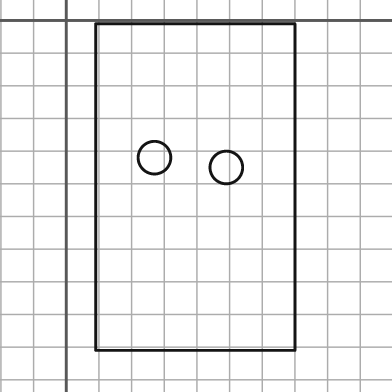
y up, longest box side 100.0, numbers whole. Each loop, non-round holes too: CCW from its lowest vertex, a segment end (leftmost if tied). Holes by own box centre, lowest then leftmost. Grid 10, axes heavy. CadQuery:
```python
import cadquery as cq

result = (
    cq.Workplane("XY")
    .moveTo(9.0, -101.0)
    .lineTo(70.0, -101.0)
    .lineTo(70.0, -1.0)
    .lineTo(9.0, -1.0)
    .close()
    .moveTo(49.0, -45.0)
    .circle(5.0)
    .moveTo(27.0, -42.0)
    .circle(5.0)
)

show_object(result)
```